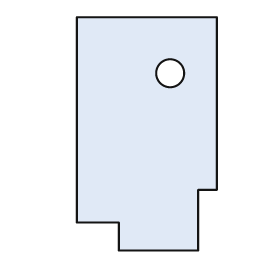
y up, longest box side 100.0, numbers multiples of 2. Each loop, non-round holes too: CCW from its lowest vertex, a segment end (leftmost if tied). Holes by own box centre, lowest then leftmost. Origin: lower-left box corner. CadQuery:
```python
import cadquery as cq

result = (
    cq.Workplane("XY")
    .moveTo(18.0, 0.0)
    .lineTo(52.0, 0.0)
    .lineTo(52.0, 26.0)
    .lineTo(60.0, 26.0)
    .lineTo(60.0, 100.0)
    .lineTo(0.0, 100.0)
    .lineTo(0.0, 12.0)
    .lineTo(18.0, 12.0)
    .close()
    .moveTo(40.0, 76.0)
    .circle(6.0)
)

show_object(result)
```